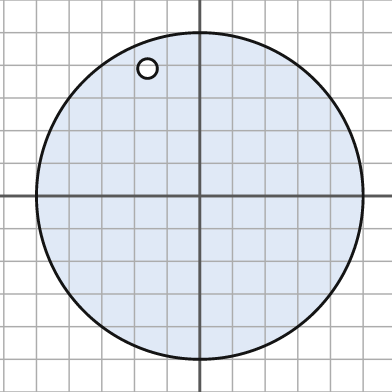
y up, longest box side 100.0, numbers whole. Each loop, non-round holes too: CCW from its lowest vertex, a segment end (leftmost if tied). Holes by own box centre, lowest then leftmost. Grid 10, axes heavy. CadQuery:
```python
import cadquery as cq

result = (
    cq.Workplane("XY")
    .moveTo(0.0, 0.0)
    .circle(50.0)
    .moveTo(-16.0, 39.0)
    .circle(3.0)
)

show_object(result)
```